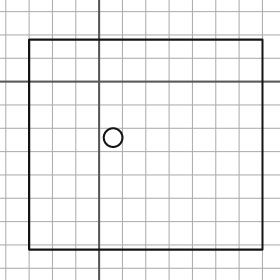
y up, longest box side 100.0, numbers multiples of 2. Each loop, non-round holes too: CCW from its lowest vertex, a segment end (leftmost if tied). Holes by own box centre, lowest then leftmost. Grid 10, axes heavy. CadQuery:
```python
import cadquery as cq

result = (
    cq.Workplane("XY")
    .moveTo(-30.0, -72.0)
    .lineTo(70.0, -72.0)
    .lineTo(70.0, 18.0)
    .lineTo(-30.0, 18.0)
    .close()
    .moveTo(6.0, -24.0)
    .circle(4.0)
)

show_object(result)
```